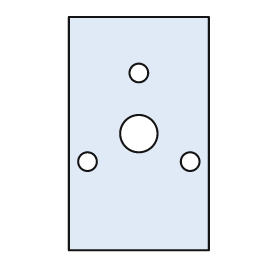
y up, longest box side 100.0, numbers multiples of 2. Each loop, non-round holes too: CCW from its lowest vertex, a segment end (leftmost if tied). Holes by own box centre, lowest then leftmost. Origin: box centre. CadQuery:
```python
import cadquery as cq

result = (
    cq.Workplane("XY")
    .moveTo(-30.0, -50.0)
    .lineTo(30.0, -50.0)
    .lineTo(30.0, 50.0)
    .lineTo(-30.0, 50.0)
    .close()
    .moveTo(-22.0, -12.0)
    .circle(4.0)
    .moveTo(22.0, -12.0)
    .circle(4.0)
    .moveTo(0.0, 0.0)
    .circle(8.0)
    .moveTo(0.0, 26.0)
    .circle(4.0)
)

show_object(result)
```